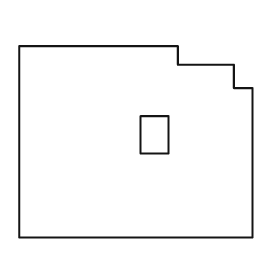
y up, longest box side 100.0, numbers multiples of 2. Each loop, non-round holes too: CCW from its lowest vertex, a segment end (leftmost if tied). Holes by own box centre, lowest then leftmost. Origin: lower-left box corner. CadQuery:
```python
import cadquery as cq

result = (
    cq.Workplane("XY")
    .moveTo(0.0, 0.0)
    .lineTo(100.0, 0.0)
    .lineTo(100.0, 64.0)
    .lineTo(92.0, 64.0)
    .lineTo(92.0, 74.0)
    .lineTo(68.0, 74.0)
    .lineTo(68.0, 82.0)
    .lineTo(0.0, 82.0)
    .close()
    .moveTo(52.0, 36.0)
    .lineTo(64.0, 36.0)
    .lineTo(64.0, 52.0)
    .lineTo(52.0, 52.0)
    .close()
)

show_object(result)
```